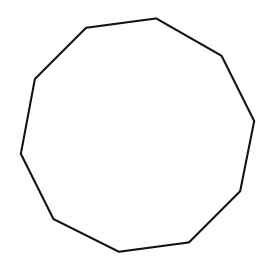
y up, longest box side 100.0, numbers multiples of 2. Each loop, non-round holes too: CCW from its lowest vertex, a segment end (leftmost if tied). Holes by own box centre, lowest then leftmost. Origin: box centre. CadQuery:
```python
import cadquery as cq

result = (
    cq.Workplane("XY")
    .moveTo(-8.0, -50.0)
    .lineTo(22.0, -46.0)
    .lineTo(44.0, -24.0)
    .lineTo(50.0, 6.0)
    .lineTo(36.0, 34.0)
    .lineTo(8.0, 50.0)
    .lineTo(-22.0, 46.0)
    .lineTo(-44.0, 24.0)
    .lineTo(-50.0, -8.0)
    .lineTo(-36.0, -36.0)
    .close()
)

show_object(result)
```